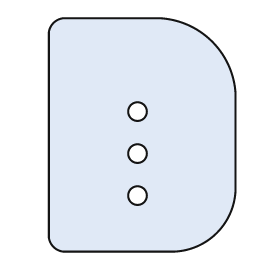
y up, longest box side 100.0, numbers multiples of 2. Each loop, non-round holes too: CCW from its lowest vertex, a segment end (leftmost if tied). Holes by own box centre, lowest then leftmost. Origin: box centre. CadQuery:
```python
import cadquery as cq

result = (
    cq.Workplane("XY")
    .moveTo(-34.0, -50.0)
    .lineTo(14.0, -50.0)
    .threePointArc((32.0, -42.0), (40.0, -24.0))
    .lineTo(40.0, 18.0)
    .threePointArc((30.0, 40.0), (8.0, 50.0))
    .lineTo(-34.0, 50.0)
    .threePointArc((-38.0, 48.0), (-40.0, 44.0))
    .lineTo(-40.0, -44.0)
    .threePointArc((-38.0, -48.0), (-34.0, -50.0))
    .close()
    .moveTo(-2.0, -26.0)
    .circle(4.0)
    .moveTo(-2.0, -8.0)
    .circle(4.0)
    .moveTo(-2.0, 10.0)
    .circle(4.0)
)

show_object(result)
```